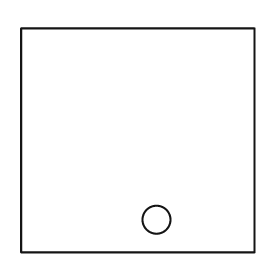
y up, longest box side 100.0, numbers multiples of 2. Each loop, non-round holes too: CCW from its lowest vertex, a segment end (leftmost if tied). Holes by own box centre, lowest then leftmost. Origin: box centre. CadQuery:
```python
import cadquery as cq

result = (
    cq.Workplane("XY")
    .moveTo(-50.0, -48.0)
    .lineTo(50.0, -48.0)
    .lineTo(50.0, 48.0)
    .lineTo(-50.0, 48.0)
    .close()
    .moveTo(8.0, -34.0)
    .circle(6.0)
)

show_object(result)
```